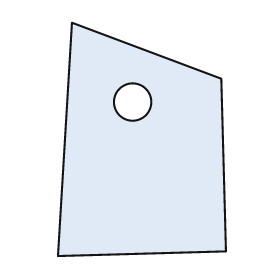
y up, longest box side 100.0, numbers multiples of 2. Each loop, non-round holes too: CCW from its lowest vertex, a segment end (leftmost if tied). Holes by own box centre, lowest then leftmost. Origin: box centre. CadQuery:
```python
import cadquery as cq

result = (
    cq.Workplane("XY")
    .moveTo(-36.0, -50.0)
    .lineTo(36.0, -48.0)
    .lineTo(34.0, 26.0)
    .lineTo(-30.0, 50.0)
    .close()
    .moveTo(-4.0, 16.0)
    .circle(8.0)
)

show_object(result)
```